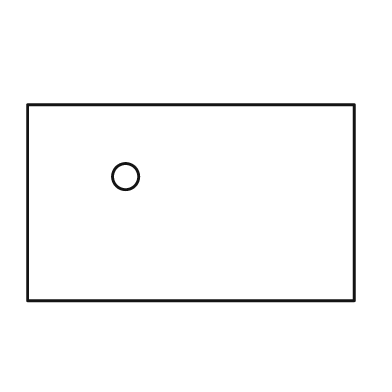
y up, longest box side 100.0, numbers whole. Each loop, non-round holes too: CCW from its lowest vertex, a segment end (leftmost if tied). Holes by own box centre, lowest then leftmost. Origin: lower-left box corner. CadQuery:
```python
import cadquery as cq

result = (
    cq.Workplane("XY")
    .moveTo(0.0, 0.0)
    .lineTo(100.0, 0.0)
    .lineTo(100.0, 60.0)
    .lineTo(0.0, 60.0)
    .close()
    .moveTo(30.0, 38.0)
    .circle(4.0)
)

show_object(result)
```